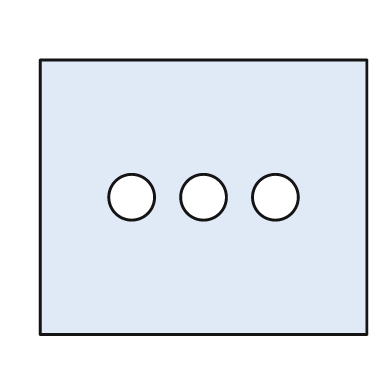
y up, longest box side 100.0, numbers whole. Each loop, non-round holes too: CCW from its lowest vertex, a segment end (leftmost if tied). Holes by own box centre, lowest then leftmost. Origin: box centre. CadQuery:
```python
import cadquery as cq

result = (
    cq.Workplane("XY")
    .moveTo(-50.0, -42.0)
    .lineTo(50.0, -42.0)
    .lineTo(50.0, 42.0)
    .lineTo(-50.0, 42.0)
    .close()
    .moveTo(-22.0, 0.0)
    .circle(7.0)
    .moveTo(0.0, 0.0)
    .circle(7.0)
    .moveTo(22.0, 0.0)
    .circle(7.0)
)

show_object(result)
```